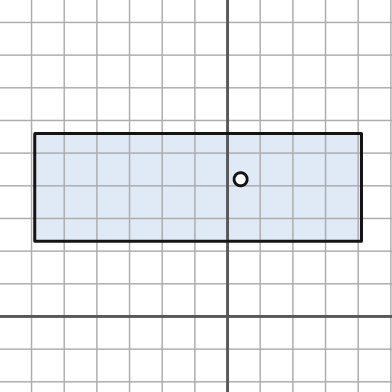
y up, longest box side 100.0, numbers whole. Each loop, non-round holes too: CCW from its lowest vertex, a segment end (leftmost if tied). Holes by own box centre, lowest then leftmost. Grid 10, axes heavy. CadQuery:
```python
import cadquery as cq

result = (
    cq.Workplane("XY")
    .moveTo(-59.0, 23.0)
    .lineTo(41.0, 23.0)
    .lineTo(41.0, 56.0)
    .lineTo(-59.0, 56.0)
    .close()
    .moveTo(4.0, 42.0)
    .circle(2.0)
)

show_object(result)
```